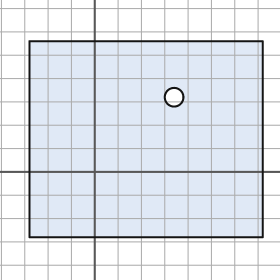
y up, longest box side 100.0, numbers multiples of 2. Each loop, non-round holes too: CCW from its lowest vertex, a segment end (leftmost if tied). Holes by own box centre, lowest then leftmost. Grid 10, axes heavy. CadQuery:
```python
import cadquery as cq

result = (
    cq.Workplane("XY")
    .moveTo(-28.0, -28.0)
    .lineTo(72.0, -28.0)
    .lineTo(72.0, 56.0)
    .lineTo(-28.0, 56.0)
    .close()
    .moveTo(34.0, 32.0)
    .circle(4.0)
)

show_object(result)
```